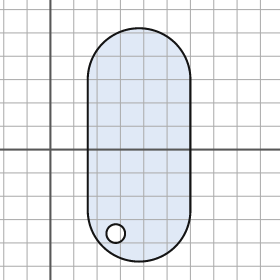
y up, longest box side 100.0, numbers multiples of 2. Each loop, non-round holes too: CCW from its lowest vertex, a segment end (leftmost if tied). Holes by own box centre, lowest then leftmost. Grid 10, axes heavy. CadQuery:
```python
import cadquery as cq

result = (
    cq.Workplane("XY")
    .moveTo(16.0, -26.0)
    .threePointArc((38.0, -48.0), (60.0, -26.0))
    .lineTo(60.0, 30.0)
    .threePointArc((38.0, 52.0), (16.0, 30.0))
    .close()
    .moveTo(28.0, -36.0)
    .circle(4.0)
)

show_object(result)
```